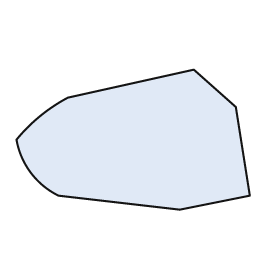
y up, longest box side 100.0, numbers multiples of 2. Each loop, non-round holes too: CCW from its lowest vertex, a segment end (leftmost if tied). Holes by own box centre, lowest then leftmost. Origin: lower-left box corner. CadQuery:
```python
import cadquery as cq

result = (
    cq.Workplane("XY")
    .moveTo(70.0, 0.0)
    .lineTo(100.0, 6.0)
    .lineTo(94.0, 44.0)
    .lineTo(76.0, 60.0)
    .lineTo(22.0, 48.0)
    .threePointArc((10.0, 40.0), (0.0, 30.0))
    .threePointArc((6.0, 16.0), (18.0, 6.0))
    .close()
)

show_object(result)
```